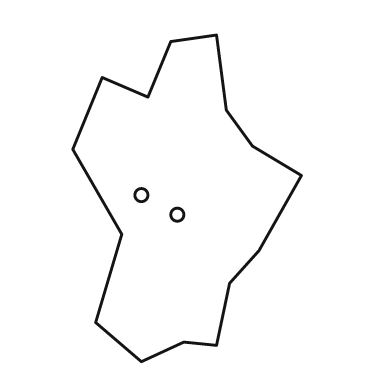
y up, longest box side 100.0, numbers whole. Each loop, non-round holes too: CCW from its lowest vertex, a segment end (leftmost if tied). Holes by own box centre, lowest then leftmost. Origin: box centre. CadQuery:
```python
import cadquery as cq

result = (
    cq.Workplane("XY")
    .moveTo(-14.0, -50.0)
    .lineTo(-1.0, -44.0)
    .lineTo(9.0, -45.0)
    .lineTo(13.0, -26.0)
    .lineTo(22.0, -16.0)
    .lineTo(35.0, 7.0)
    .lineTo(20.0, 16.0)
    .lineTo(12.0, 27.0)
    .lineTo(9.0, 50.0)
    .lineTo(-5.0, 48.0)
    .lineTo(-12.0, 31.0)
    .lineTo(-26.0, 37.0)
    .lineTo(-35.0, 15.0)
    .lineTo(-20.0, -11.0)
    .lineTo(-28.0, -38.0)
    .close()
    .moveTo(-3.0, -5.0)
    .circle(2.0)
    .moveTo(-14.0, 1.0)
    .circle(2.0)
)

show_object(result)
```